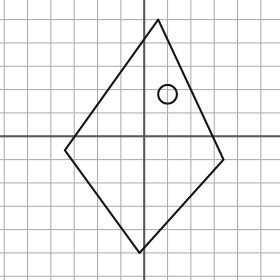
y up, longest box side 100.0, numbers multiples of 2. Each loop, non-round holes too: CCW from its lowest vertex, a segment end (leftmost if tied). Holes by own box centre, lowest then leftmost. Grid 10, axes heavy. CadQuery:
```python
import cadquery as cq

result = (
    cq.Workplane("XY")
    .moveTo(-2.0, -50.0)
    .lineTo(34.0, -10.0)
    .lineTo(6.0, 50.0)
    .lineTo(-34.0, -6.0)
    .close()
    .moveTo(10.0, 18.0)
    .circle(4.0)
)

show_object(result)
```